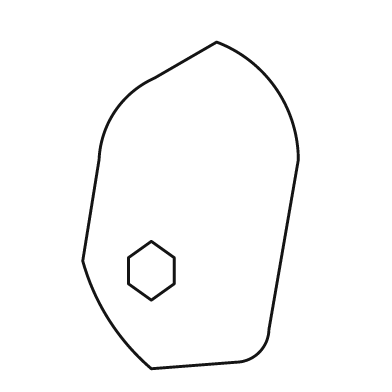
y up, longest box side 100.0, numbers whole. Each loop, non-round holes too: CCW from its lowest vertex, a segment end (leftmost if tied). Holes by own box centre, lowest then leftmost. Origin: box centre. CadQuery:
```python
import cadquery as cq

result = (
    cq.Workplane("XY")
    .moveTo(-12.0, -50.0)
    .lineTo(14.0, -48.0)
    .threePointArc((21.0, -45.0), (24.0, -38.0))
    .lineTo(33.0, 14.0)
    .threePointArc((26.0, 36.0), (8.0, 50.0))
    .lineTo(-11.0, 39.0)
    .threePointArc((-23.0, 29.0), (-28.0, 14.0))
    .lineTo(-33.0, -17.0)
    .threePointArc((-25.0, -35.0), (-12.0, -50.0))
    .close()
    .moveTo(-12.0, -29.0)
    .lineTo(-5.0, -24.0)
    .lineTo(-5.0, -16.0)
    .lineTo(-12.0, -11.0)
    .lineTo(-19.0, -16.0)
    .lineTo(-19.0, -24.0)
    .close()
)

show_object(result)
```